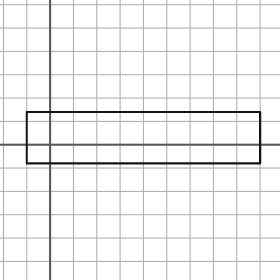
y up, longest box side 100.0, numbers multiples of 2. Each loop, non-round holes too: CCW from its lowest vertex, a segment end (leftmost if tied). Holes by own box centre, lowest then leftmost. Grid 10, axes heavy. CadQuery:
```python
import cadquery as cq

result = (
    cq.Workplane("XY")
    .moveTo(-10.0, -8.0)
    .lineTo(90.0, -8.0)
    .lineTo(90.0, 14.0)
    .lineTo(-10.0, 14.0)
    .close()
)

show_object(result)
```